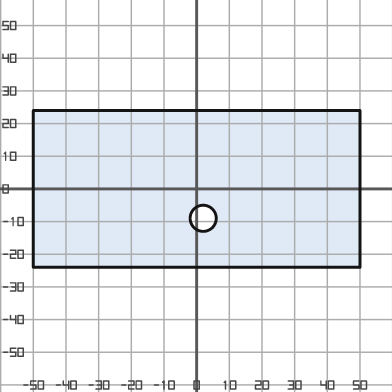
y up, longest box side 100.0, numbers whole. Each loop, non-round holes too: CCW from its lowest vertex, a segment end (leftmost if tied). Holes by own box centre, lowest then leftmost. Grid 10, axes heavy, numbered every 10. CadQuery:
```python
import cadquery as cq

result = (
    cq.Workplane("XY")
    .moveTo(-50.0, -24.0)
    .lineTo(50.0, -24.0)
    .lineTo(50.0, 24.0)
    .lineTo(-50.0, 24.0)
    .close()
    .moveTo(2.0, -9.0)
    .circle(4.0)
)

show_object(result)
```